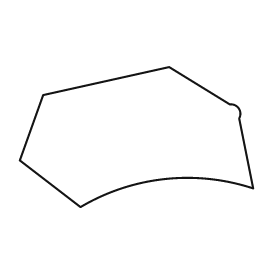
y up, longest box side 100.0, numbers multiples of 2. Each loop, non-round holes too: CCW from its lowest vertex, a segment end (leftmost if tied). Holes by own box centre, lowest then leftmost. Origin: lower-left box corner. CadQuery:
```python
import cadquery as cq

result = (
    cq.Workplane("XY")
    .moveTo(26.0, 0.0)
    .threePointArc((62.0, 12.0), (100.0, 8.0))
    .lineTo(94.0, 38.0)
    .threePointArc((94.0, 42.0), (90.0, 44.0))
    .lineTo(64.0, 60.0)
    .lineTo(10.0, 48.0)
    .lineTo(0.0, 20.0)
    .close()
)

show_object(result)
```